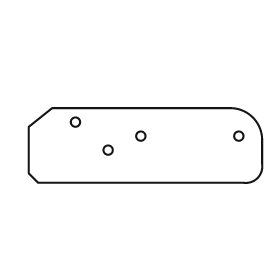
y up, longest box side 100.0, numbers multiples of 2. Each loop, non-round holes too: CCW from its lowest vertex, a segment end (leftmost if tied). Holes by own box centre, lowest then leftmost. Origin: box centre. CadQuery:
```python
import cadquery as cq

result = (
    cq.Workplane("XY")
    .moveTo(-46.0, -16.0)
    .lineTo(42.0, -16.0)
    .threePointArc((48.0, -14.0), (50.0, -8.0))
    .lineTo(50.0, 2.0)
    .threePointArc((46.0, 12.0), (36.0, 16.0))
    .lineTo(-40.0, 16.0)
    .lineTo(-50.0, 8.0)
    .lineTo(-50.0, -12.0)
    .close()
    .moveTo(-16.0, -2.0)
    .circle(2.0)
    .moveTo(-2.0, 4.0)
    .circle(2.0)
    .moveTo(40.0, 4.0)
    .circle(2.0)
    .moveTo(-30.0, 10.0)
    .circle(2.0)
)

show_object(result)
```